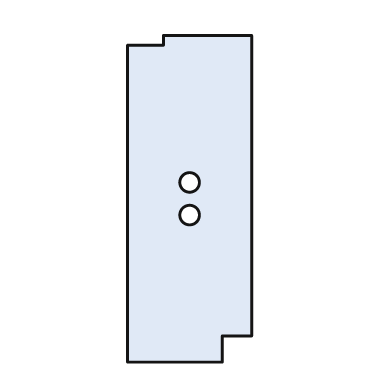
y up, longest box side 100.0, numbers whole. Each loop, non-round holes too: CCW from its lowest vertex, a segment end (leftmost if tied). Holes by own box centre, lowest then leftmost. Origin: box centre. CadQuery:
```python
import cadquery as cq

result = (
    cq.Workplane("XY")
    .moveTo(-19.0, -50.0)
    .lineTo(10.0, -50.0)
    .lineTo(10.0, -42.0)
    .lineTo(19.0, -42.0)
    .lineTo(19.0, 50.0)
    .lineTo(-8.0, 50.0)
    .lineTo(-8.0, 47.0)
    .lineTo(-19.0, 47.0)
    .close()
    .moveTo(0.0, -5.0)
    .circle(3.0)
    .moveTo(0.0, 5.0)
    .circle(3.0)
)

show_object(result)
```